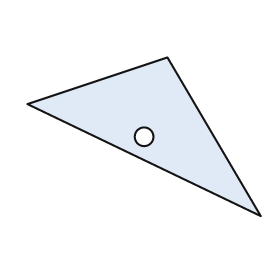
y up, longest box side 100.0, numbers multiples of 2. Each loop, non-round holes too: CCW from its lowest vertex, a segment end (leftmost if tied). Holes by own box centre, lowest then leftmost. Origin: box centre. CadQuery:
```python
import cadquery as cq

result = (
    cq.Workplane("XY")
    .moveTo(50.0, -34.0)
    .lineTo(10.0, 34.0)
    .lineTo(-50.0, 14.0)
    .close()
    .moveTo(0.0, 0.0)
    .circle(4.0)
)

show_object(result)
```